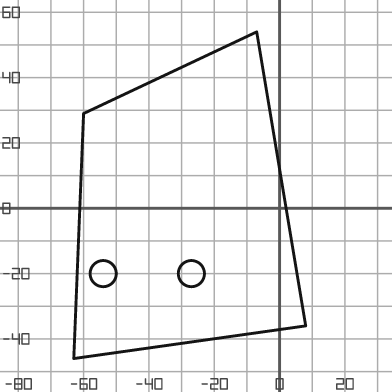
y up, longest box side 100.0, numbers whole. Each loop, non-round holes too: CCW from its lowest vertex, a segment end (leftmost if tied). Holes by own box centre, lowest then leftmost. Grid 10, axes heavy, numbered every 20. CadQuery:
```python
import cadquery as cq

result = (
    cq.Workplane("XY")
    .moveTo(-63.0, -46.0)
    .lineTo(8.0, -36.0)
    .lineTo(-7.0, 54.0)
    .lineTo(-60.0, 29.0)
    .close()
    .moveTo(-54.0, -20.0)
    .circle(4.0)
    .moveTo(-27.0, -20.0)
    .circle(4.0)
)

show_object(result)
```